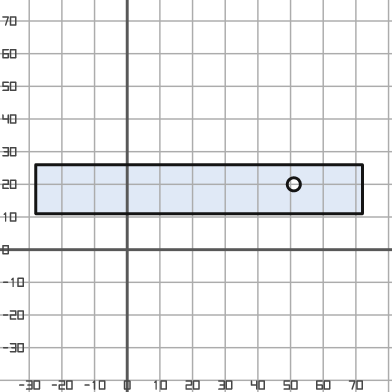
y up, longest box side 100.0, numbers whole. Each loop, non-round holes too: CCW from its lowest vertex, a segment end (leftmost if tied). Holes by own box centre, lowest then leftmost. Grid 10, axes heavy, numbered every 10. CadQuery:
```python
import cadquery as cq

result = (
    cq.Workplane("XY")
    .moveTo(-28.0, 11.0)
    .lineTo(72.0, 11.0)
    .lineTo(72.0, 26.0)
    .lineTo(-28.0, 26.0)
    .close()
    .moveTo(51.0, 20.0)
    .circle(2.0)
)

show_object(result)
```